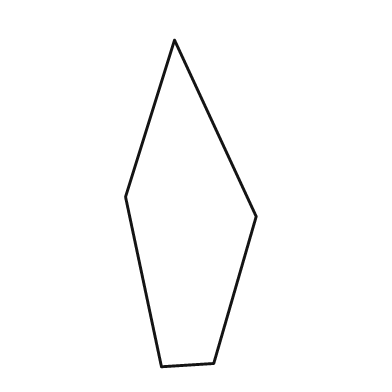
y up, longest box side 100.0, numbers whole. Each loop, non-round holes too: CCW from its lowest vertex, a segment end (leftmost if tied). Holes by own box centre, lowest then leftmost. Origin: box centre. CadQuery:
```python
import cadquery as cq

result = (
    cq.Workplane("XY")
    .moveTo(-9.0, -50.0)
    .lineTo(7.0, -49.0)
    .lineTo(20.0, -4.0)
    .lineTo(-5.0, 50.0)
    .lineTo(-20.0, 2.0)
    .close()
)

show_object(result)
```